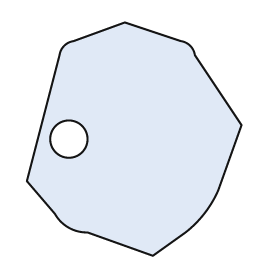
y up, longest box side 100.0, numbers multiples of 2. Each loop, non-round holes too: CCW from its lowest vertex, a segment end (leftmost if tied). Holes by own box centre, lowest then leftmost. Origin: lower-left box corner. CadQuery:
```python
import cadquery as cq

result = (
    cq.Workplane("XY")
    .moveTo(54.0, 0.0)
    .lineTo(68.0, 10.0)
    .threePointArc((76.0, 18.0), (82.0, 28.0))
    .lineTo(92.0, 56.0)
    .lineTo(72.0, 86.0)
    .threePointArc((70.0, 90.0), (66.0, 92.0))
    .lineTo(42.0, 100.0)
    .lineTo(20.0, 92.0)
    .threePointArc((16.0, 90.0), (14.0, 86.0))
    .lineTo(0.0, 32.0)
    .lineTo(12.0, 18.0)
    .threePointArc((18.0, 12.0), (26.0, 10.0))
    .close()
    .moveTo(18.0, 50.0)
    .circle(8.0)
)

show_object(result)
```